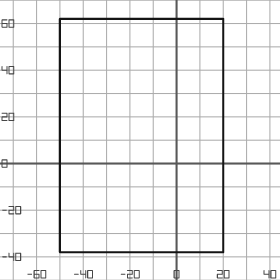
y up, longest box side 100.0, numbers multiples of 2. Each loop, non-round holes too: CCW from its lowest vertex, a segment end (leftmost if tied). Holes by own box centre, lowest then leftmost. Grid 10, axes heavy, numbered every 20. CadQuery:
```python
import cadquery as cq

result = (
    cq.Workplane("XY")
    .moveTo(-50.0, -38.0)
    .lineTo(20.0, -38.0)
    .lineTo(20.0, 62.0)
    .lineTo(-50.0, 62.0)
    .close()
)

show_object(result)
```